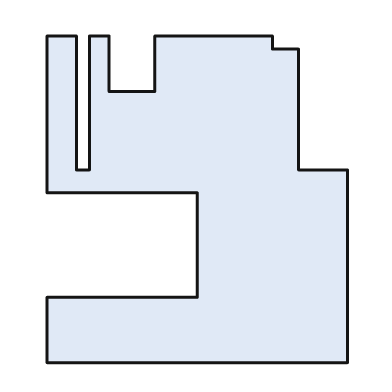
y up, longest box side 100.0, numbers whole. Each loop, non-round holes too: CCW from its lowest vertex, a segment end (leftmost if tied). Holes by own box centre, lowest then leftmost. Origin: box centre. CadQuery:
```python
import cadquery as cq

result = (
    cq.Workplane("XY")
    .moveTo(-46.0, -50.0)
    .lineTo(46.0, -50.0)
    .lineTo(46.0, 9.0)
    .lineTo(31.0, 9.0)
    .lineTo(31.0, 46.0)
    .lineTo(23.0, 46.0)
    .lineTo(23.0, 50.0)
    .lineTo(-13.0, 50.0)
    .lineTo(-13.0, 33.0)
    .lineTo(-27.0, 33.0)
    .lineTo(-27.0, 50.0)
    .lineTo(-33.0, 50.0)
    .lineTo(-33.0, 9.0)
    .lineTo(-37.0, 9.0)
    .lineTo(-37.0, 50.0)
    .lineTo(-46.0, 50.0)
    .lineTo(-46.0, 2.0)
    .lineTo(0.0, 2.0)
    .lineTo(0.0, -30.0)
    .lineTo(-46.0, -30.0)
    .close()
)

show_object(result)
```